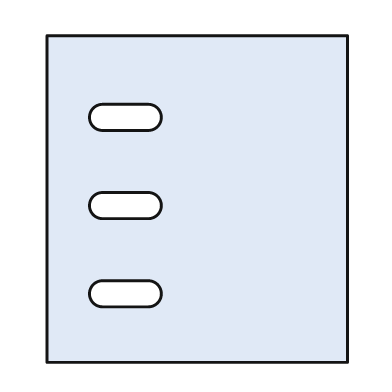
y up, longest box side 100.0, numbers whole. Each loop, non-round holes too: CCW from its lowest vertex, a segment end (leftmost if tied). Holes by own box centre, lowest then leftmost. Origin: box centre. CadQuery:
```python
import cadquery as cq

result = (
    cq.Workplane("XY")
    .moveTo(-46.0, -50.0)
    .lineTo(46.0, -50.0)
    .lineTo(46.0, 50.0)
    .lineTo(-46.0, 50.0)
    .close()
    .moveTo(-29.0, -33.0)
    .lineTo(-15.0, -33.0)
    .threePointArc((-11.0, -29.0), (-15.0, -25.0))
    .lineTo(-29.0, -25.0)
    .threePointArc((-33.0, -29.0), (-29.0, -33.0))
    .close()
    .moveTo(-29.0, -6.0)
    .lineTo(-15.0, -6.0)
    .threePointArc((-11.0, -2.0), (-15.0, 2.0))
    .lineTo(-29.0, 2.0)
    .threePointArc((-33.0, -2.0), (-29.0, -6.0))
    .close()
    .moveTo(-29.0, 21.0)
    .lineTo(-15.0, 21.0)
    .threePointArc((-11.0, 25.0), (-15.0, 29.0))
    .lineTo(-29.0, 29.0)
    .threePointArc((-33.0, 25.0), (-29.0, 21.0))
    .close()
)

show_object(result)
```